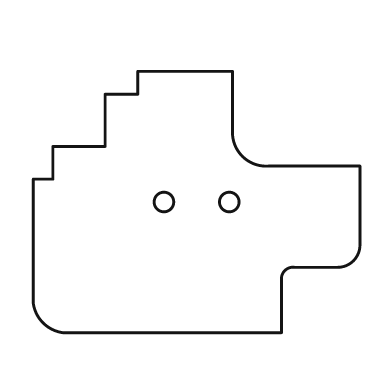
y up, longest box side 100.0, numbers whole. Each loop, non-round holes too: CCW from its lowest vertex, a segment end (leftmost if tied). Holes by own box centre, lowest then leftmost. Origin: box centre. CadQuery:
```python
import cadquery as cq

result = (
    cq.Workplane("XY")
    .moveTo(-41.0, -40.0)
    .lineTo(26.0, -40.0)
    .lineTo(26.0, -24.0)
    .threePointArc((27.0, -21.0), (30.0, -20.0))
    .lineTo(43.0, -20.0)
    .threePointArc((48.0, -18.0), (50.0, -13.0))
    .lineTo(50.0, 11.0)
    .lineTo(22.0, 11.0)
    .threePointArc((14.0, 14.0), (11.0, 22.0))
    .lineTo(11.0, 40.0)
    .lineTo(-18.0, 40.0)
    .lineTo(-18.0, 33.0)
    .lineTo(-28.0, 33.0)
    .lineTo(-28.0, 17.0)
    .lineTo(-44.0, 17.0)
    .lineTo(-44.0, 7.0)
    .lineTo(-50.0, 7.0)
    .lineTo(-50.0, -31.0)
    .threePointArc((-47.0, -37.0), (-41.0, -40.0))
    .close()
    .moveTo(-10.0, 0.0)
    .circle(3.0)
    .moveTo(10.0, 0.0)
    .circle(3.0)
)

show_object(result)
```